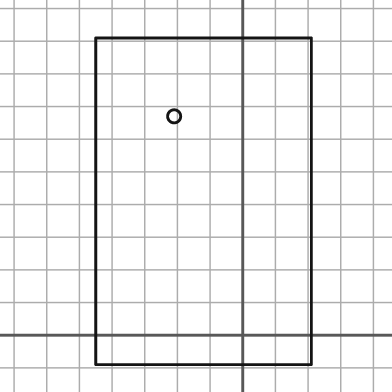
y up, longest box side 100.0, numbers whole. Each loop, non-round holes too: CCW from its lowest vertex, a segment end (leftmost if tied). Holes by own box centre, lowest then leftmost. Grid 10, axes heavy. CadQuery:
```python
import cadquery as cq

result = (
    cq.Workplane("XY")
    .moveTo(-45.0, -9.0)
    .lineTo(21.0, -9.0)
    .lineTo(21.0, 91.0)
    .lineTo(-45.0, 91.0)
    .close()
    .moveTo(-21.0, 67.0)
    .circle(2.0)
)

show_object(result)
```